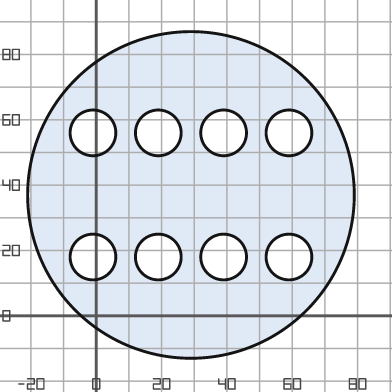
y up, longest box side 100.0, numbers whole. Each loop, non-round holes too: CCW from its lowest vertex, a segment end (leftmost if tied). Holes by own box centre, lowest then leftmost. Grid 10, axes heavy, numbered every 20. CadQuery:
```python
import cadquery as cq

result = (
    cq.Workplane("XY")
    .moveTo(29.0, 37.0)
    .circle(50.0)
    .moveTo(-1.0, 18.0)
    .circle(7.0)
    .moveTo(19.0, 18.0)
    .circle(7.0)
    .moveTo(39.0, 18.0)
    .circle(7.0)
    .moveTo(59.0, 18.0)
    .circle(7.0)
    .moveTo(-1.0, 56.0)
    .circle(7.0)
    .moveTo(19.0, 56.0)
    .circle(7.0)
    .moveTo(39.0, 56.0)
    .circle(7.0)
    .moveTo(59.0, 56.0)
    .circle(7.0)
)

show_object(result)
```